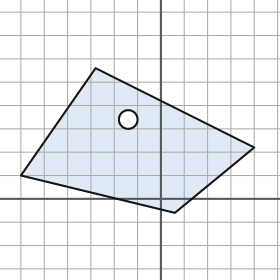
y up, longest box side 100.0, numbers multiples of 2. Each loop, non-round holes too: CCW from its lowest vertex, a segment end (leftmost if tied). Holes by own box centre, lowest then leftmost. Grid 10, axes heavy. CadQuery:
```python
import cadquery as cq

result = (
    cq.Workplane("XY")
    .moveTo(6.0, -6.0)
    .lineTo(40.0, 22.0)
    .lineTo(-28.0, 56.0)
    .lineTo(-60.0, 10.0)
    .close()
    .moveTo(-14.0, 34.0)
    .circle(4.0)
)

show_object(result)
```